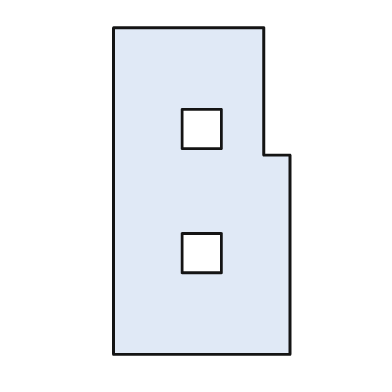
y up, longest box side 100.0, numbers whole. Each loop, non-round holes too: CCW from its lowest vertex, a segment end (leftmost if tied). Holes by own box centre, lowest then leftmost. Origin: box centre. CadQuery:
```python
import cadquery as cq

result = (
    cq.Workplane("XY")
    .moveTo(-27.0, -50.0)
    .lineTo(27.0, -50.0)
    .lineTo(27.0, 11.0)
    .lineTo(19.0, 11.0)
    .lineTo(19.0, 50.0)
    .lineTo(-27.0, 50.0)
    .close()
    .moveTo(-6.0, -25.0)
    .lineTo(6.0, -25.0)
    .lineTo(6.0, -13.0)
    .lineTo(-6.0, -13.0)
    .close()
    .moveTo(-6.0, 13.0)
    .lineTo(6.0, 13.0)
    .lineTo(6.0, 25.0)
    .lineTo(-6.0, 25.0)
    .close()
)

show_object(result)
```